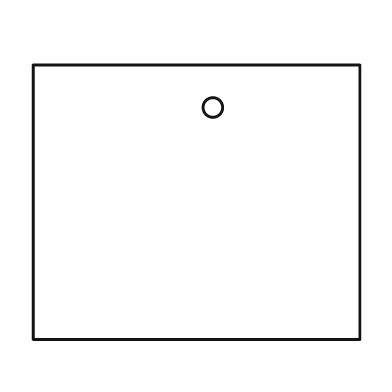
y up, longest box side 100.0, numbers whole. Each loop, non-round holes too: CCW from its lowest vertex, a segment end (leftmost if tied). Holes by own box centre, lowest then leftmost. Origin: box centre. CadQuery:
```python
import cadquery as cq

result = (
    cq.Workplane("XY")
    .moveTo(-50.0, -42.0)
    .lineTo(50.0, -42.0)
    .lineTo(50.0, 42.0)
    .lineTo(-50.0, 42.0)
    .close()
    .moveTo(5.0, 29.0)
    .circle(3.0)
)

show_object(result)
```